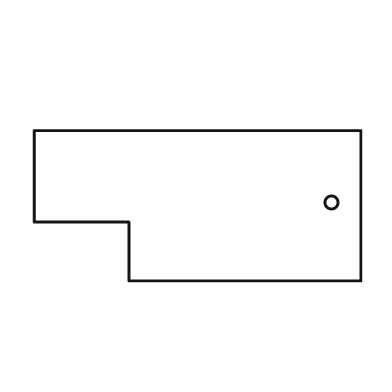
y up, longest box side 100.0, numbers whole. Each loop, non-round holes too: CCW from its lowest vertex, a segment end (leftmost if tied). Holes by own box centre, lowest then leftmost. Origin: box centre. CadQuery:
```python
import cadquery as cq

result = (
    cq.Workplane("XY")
    .moveTo(-21.0, -23.0)
    .lineTo(50.0, -23.0)
    .lineTo(50.0, 23.0)
    .lineTo(-50.0, 23.0)
    .lineTo(-50.0, -5.0)
    .lineTo(-21.0, -5.0)
    .close()
    .moveTo(41.0, 1.0)
    .circle(2.0)
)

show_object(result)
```